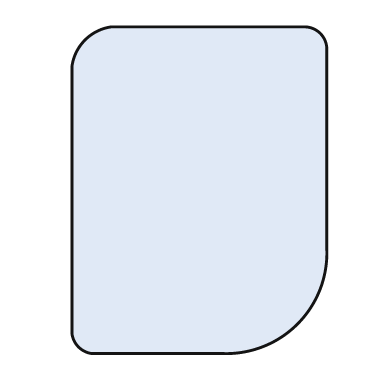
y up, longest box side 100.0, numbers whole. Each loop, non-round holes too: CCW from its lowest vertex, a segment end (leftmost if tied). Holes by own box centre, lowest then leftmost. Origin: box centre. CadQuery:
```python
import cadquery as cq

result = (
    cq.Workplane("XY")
    .moveTo(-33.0, -50.0)
    .lineTo(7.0, -50.0)
    .threePointArc((30.0, -41.0), (39.0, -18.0))
    .lineTo(39.0, 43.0)
    .threePointArc((37.0, 48.0), (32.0, 50.0))
    .lineTo(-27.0, 50.0)
    .threePointArc((-35.0, 46.0), (-39.0, 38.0))
    .lineTo(-39.0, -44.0)
    .threePointArc((-37.0, -48.0), (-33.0, -50.0))
    .close()
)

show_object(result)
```